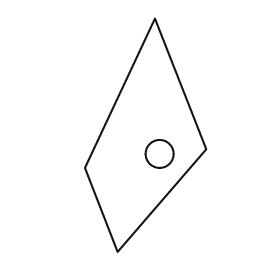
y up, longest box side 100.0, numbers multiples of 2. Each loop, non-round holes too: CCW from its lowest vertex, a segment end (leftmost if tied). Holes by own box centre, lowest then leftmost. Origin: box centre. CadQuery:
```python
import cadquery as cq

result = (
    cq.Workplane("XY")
    .moveTo(-12.0, -50.0)
    .lineTo(26.0, -6.0)
    .lineTo(4.0, 50.0)
    .lineTo(-26.0, -14.0)
    .close()
    .moveTo(6.0, -8.0)
    .circle(6.0)
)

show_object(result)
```